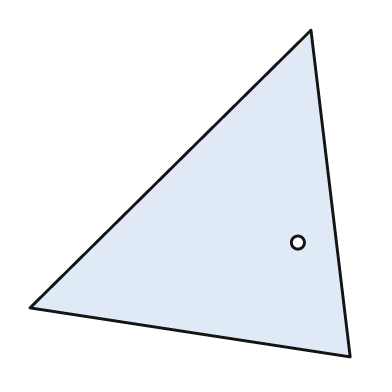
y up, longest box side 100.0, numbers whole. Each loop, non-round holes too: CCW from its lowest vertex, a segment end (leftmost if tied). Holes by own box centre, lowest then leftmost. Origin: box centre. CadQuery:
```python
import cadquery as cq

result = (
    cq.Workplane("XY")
    .moveTo(49.0, -50.0)
    .lineTo(37.0, 50.0)
    .lineTo(-49.0, -35.0)
    .close()
    .moveTo(33.0, -15.0)
    .circle(2.0)
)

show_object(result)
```